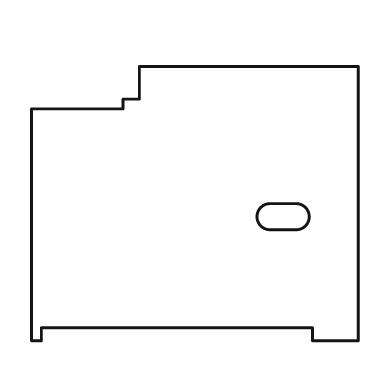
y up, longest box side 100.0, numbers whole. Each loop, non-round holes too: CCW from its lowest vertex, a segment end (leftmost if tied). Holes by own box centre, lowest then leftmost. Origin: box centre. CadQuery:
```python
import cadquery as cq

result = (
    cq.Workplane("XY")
    .moveTo(-50.0, -42.0)
    .lineTo(-47.0, -42.0)
    .lineTo(-47.0, -38.0)
    .lineTo(36.0, -38.0)
    .lineTo(36.0, -42.0)
    .lineTo(50.0, -42.0)
    .lineTo(50.0, 42.0)
    .lineTo(-17.0, 42.0)
    .lineTo(-17.0, 32.0)
    .lineTo(-22.0, 32.0)
    .lineTo(-22.0, 29.0)
    .lineTo(-50.0, 29.0)
    .close()
    .moveTo(23.0, -8.0)
    .lineTo(31.0, -8.0)
    .threePointArc((35.0, -4.0), (31.0, 0.0))
    .lineTo(23.0, 0.0)
    .threePointArc((19.0, -4.0), (23.0, -8.0))
    .close()
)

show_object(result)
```